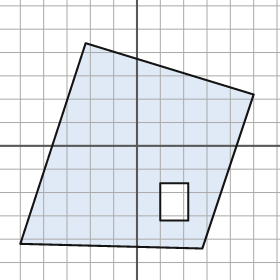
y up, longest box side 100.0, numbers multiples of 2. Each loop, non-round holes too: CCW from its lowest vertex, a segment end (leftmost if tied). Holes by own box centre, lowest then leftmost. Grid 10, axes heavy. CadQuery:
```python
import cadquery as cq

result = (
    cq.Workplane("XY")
    .moveTo(28.0, -44.0)
    .lineTo(50.0, 22.0)
    .lineTo(-22.0, 44.0)
    .lineTo(-50.0, -42.0)
    .close()
    .moveTo(10.0, -32.0)
    .lineTo(22.0, -32.0)
    .lineTo(22.0, -16.0)
    .lineTo(10.0, -16.0)
    .close()
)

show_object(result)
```